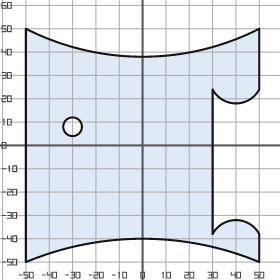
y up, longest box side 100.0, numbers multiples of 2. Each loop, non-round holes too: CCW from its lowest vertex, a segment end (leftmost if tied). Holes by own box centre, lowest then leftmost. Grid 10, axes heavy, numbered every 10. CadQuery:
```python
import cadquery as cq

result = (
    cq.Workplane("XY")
    .moveTo(-50.0, -50.0)
    .threePointArc((0.0, -40.0), (50.0, -50.0))
    .lineTo(50.0, -38.0)
    .threePointArc((40.0, -32.0), (30.0, -38.0))
    .lineTo(30.0, 24.0)
    .threePointArc((40.0, 18.0), (50.0, 24.0))
    .lineTo(50.0, 50.0)
    .threePointArc((0.0, 38.0), (-50.0, 50.0))
    .close()
    .moveTo(-30.0, 8.0)
    .circle(4.0)
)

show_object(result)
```